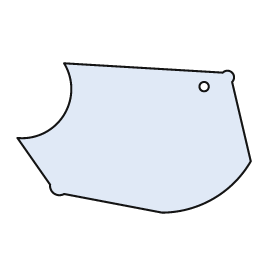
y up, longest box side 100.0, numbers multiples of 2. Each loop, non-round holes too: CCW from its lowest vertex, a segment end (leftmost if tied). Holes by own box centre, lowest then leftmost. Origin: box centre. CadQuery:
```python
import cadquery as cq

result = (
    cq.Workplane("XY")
    .moveTo(12.0, -32.0)
    .threePointArc((34.0, -26.0), (50.0, -10.0))
    .lineTo(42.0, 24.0)
    .threePointArc((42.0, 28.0), (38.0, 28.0))
    .lineTo(-30.0, 32.0)
    .threePointArc((-30.0, 10.0), (-50.0, 0.0))
    .lineTo(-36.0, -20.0)
    .threePointArc((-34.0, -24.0), (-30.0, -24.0))
    .close()
    .moveTo(30.0, 22.0)
    .circle(2.0)
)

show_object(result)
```